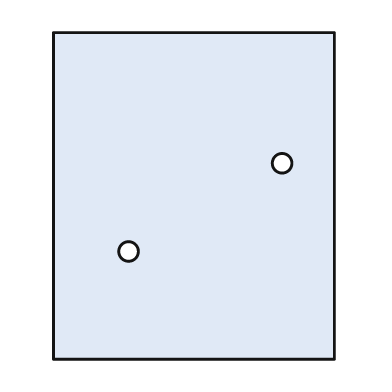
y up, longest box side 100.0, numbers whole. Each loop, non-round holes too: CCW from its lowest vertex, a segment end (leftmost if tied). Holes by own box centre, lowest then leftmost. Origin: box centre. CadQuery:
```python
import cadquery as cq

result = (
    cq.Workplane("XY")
    .moveTo(-43.0, -50.0)
    .lineTo(43.0, -50.0)
    .lineTo(43.0, 50.0)
    .lineTo(-43.0, 50.0)
    .close()
    .moveTo(-20.0, -17.0)
    .circle(3.0)
    .moveTo(27.0, 10.0)
    .circle(3.0)
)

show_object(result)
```